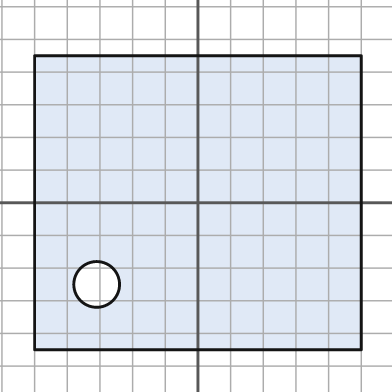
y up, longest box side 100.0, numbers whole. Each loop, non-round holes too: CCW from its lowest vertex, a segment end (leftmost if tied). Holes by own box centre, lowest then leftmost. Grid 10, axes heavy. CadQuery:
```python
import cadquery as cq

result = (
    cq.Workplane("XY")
    .moveTo(-50.0, -45.0)
    .lineTo(50.0, -45.0)
    .lineTo(50.0, 45.0)
    .lineTo(-50.0, 45.0)
    .close()
    .moveTo(-31.0, -25.0)
    .circle(7.0)
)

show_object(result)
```